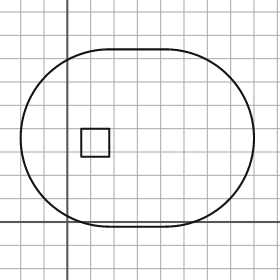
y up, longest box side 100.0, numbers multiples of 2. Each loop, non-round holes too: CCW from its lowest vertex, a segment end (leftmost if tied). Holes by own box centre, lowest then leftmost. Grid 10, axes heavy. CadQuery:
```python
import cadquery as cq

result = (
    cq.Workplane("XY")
    .moveTo(18.0, -2.0)
    .lineTo(42.0, -2.0)
    .threePointArc((80.0, 36.0), (42.0, 74.0))
    .lineTo(18.0, 74.0)
    .threePointArc((-20.0, 36.0), (18.0, -2.0))
    .close()
    .moveTo(6.0, 28.0)
    .lineTo(18.0, 28.0)
    .lineTo(18.0, 40.0)
    .lineTo(6.0, 40.0)
    .close()
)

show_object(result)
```